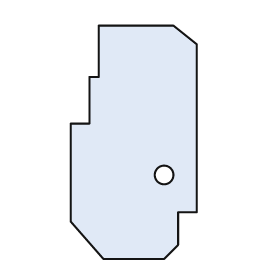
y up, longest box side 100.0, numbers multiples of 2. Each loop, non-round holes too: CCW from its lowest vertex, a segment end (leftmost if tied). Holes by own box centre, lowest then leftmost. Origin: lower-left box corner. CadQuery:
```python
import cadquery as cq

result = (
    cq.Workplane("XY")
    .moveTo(14.0, 0.0)
    .lineTo(40.0, 0.0)
    .lineTo(46.0, 6.0)
    .lineTo(46.0, 20.0)
    .lineTo(54.0, 20.0)
    .lineTo(54.0, 92.0)
    .lineTo(44.0, 100.0)
    .lineTo(12.0, 100.0)
    .lineTo(12.0, 78.0)
    .lineTo(8.0, 78.0)
    .lineTo(8.0, 58.0)
    .lineTo(0.0, 58.0)
    .lineTo(0.0, 16.0)
    .close()
    .moveTo(40.0, 36.0)
    .circle(4.0)
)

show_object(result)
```